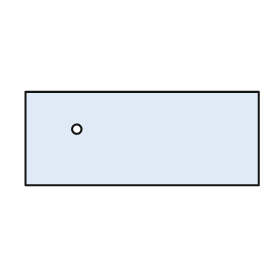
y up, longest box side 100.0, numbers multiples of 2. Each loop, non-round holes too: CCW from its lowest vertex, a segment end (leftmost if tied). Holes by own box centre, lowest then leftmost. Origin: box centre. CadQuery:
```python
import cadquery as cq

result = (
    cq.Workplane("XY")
    .moveTo(-50.0, -20.0)
    .lineTo(50.0, -20.0)
    .lineTo(50.0, 20.0)
    .lineTo(-50.0, 20.0)
    .close()
    .moveTo(-28.0, 4.0)
    .circle(2.0)
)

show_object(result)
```